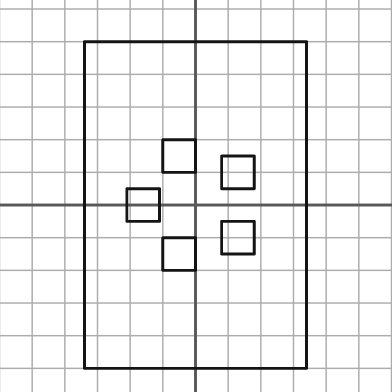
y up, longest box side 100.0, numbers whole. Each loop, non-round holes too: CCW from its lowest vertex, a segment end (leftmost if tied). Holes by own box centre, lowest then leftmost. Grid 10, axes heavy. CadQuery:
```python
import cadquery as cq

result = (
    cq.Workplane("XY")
    .moveTo(-34.0, -50.0)
    .lineTo(34.0, -50.0)
    .lineTo(34.0, 50.0)
    .lineTo(-34.0, 50.0)
    .close()
    .moveTo(-10.0, -20.0)
    .lineTo(0.0, -20.0)
    .lineTo(0.0, -10.0)
    .lineTo(-10.0, -10.0)
    .close()
    .moveTo(8.0, -15.0)
    .lineTo(18.0, -15.0)
    .lineTo(18.0, -5.0)
    .lineTo(8.0, -5.0)
    .close()
    .moveTo(-21.0, -5.0)
    .lineTo(-11.0, -5.0)
    .lineTo(-11.0, 5.0)
    .lineTo(-21.0, 5.0)
    .close()
    .moveTo(8.0, 5.0)
    .lineTo(18.0, 5.0)
    .lineTo(18.0, 15.0)
    .lineTo(8.0, 15.0)
    .close()
    .moveTo(-10.0, 10.0)
    .lineTo(0.0, 10.0)
    .lineTo(0.0, 20.0)
    .lineTo(-10.0, 20.0)
    .close()
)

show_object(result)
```